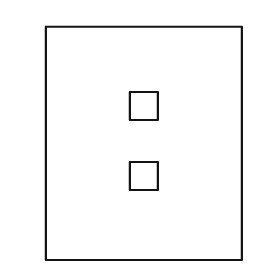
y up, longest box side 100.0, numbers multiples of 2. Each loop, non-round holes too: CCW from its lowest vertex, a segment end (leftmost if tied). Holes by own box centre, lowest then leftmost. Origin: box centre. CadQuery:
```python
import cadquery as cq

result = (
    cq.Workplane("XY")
    .moveTo(-42.0, -50.0)
    .lineTo(42.0, -50.0)
    .lineTo(42.0, 50.0)
    .lineTo(-42.0, 50.0)
    .close()
    .moveTo(-6.0, -20.0)
    .lineTo(6.0, -20.0)
    .lineTo(6.0, -8.0)
    .lineTo(-6.0, -8.0)
    .close()
    .moveTo(-6.0, 10.0)
    .lineTo(6.0, 10.0)
    .lineTo(6.0, 22.0)
    .lineTo(-6.0, 22.0)
    .close()
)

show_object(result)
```